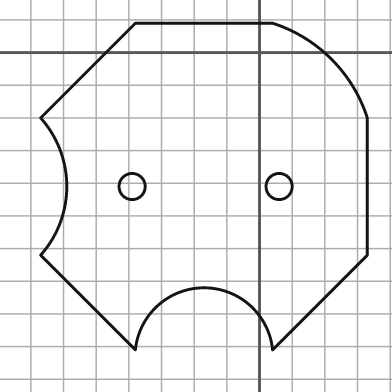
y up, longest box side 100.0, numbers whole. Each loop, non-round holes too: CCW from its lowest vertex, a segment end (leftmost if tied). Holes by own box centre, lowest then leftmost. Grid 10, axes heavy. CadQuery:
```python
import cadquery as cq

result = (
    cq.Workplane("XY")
    .moveTo(-38.0, -91.0)
    .threePointArc((-17.0, -72.0), (4.0, -91.0))
    .lineTo(33.0, -62.0)
    .lineTo(33.0, -20.0)
    .threePointArc((22.0, -2.0), (4.0, 9.0))
    .lineTo(-38.0, 9.0)
    .lineTo(-67.0, -20.0)
    .threePointArc((-59.0, -41.0), (-67.0, -62.0))
    .close()
    .moveTo(-39.0, -41.0)
    .circle(4.0)
    .moveTo(6.0, -41.0)
    .circle(4.0)
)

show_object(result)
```